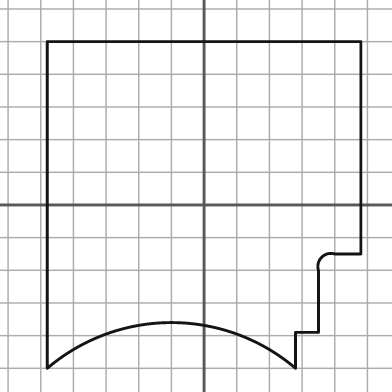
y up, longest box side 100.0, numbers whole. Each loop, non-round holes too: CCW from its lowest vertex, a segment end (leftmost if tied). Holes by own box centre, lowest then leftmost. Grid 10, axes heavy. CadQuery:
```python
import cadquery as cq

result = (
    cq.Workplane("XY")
    .moveTo(-48.0, -50.0)
    .threePointArc((-10.0, -36.0), (28.0, -50.0))
    .lineTo(28.0, -39.0)
    .lineTo(35.0, -39.0)
    .lineTo(35.0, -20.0)
    .threePointArc((36.0, -16.0), (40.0, -15.0))
    .lineTo(48.0, -15.0)
    .lineTo(48.0, 50.0)
    .lineTo(-48.0, 50.0)
    .close()
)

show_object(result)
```